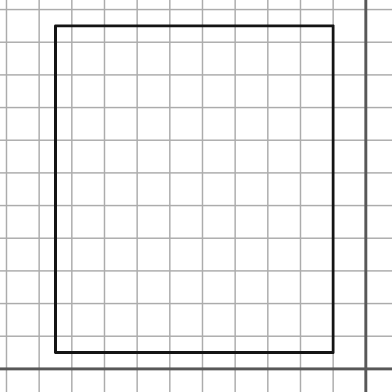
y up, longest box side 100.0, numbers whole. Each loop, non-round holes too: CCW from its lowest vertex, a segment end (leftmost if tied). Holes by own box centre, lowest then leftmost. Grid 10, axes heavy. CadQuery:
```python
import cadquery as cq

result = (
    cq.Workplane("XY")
    .moveTo(-95.0, 5.0)
    .lineTo(-10.0, 5.0)
    .lineTo(-10.0, 105.0)
    .lineTo(-95.0, 105.0)
    .close()
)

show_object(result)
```